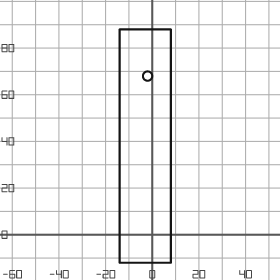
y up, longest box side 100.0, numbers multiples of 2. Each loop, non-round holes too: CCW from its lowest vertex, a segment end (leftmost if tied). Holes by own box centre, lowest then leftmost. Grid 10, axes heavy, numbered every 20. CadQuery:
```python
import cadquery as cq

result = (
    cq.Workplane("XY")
    .moveTo(-14.0, -12.0)
    .lineTo(8.0, -12.0)
    .lineTo(8.0, 88.0)
    .lineTo(-14.0, 88.0)
    .close()
    .moveTo(-2.0, 68.0)
    .circle(2.0)
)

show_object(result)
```